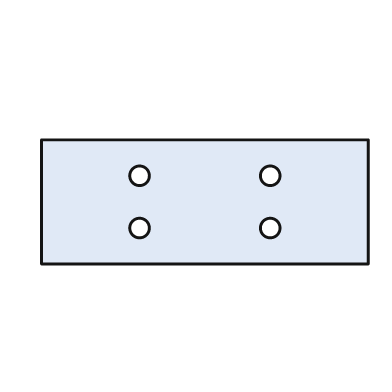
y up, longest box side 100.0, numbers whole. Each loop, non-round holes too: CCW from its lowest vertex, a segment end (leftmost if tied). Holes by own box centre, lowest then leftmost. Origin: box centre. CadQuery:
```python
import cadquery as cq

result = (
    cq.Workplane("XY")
    .moveTo(-50.0, -19.0)
    .lineTo(50.0, -19.0)
    .lineTo(50.0, 19.0)
    .lineTo(-50.0, 19.0)
    .close()
    .moveTo(-20.0, -8.0)
    .circle(3.0)
    .moveTo(20.0, -8.0)
    .circle(3.0)
    .moveTo(-20.0, 8.0)
    .circle(3.0)
    .moveTo(20.0, 8.0)
    .circle(3.0)
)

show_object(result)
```